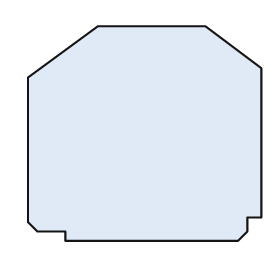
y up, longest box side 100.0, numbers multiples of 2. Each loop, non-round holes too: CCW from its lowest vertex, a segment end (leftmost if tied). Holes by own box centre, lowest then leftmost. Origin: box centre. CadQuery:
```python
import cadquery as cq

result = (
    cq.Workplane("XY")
    .moveTo(-34.0, -46.0)
    .lineTo(40.0, -46.0)
    .lineTo(44.0, -42.0)
    .lineTo(44.0, -36.0)
    .lineTo(50.0, -36.0)
    .lineTo(50.0, 28.0)
    .lineTo(26.0, 46.0)
    .lineTo(-20.0, 46.0)
    .lineTo(-50.0, 24.0)
    .lineTo(-50.0, -38.0)
    .lineTo(-46.0, -42.0)
    .lineTo(-34.0, -42.0)
    .close()
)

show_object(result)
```